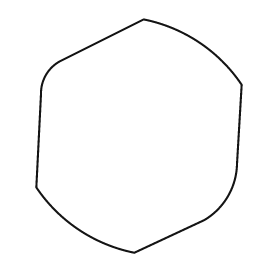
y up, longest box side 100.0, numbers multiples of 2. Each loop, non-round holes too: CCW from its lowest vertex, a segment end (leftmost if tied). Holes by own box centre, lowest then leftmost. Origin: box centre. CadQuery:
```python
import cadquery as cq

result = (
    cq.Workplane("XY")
    .moveTo(-2.0, -50.0)
    .lineTo(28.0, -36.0)
    .threePointArc((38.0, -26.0), (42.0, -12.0))
    .lineTo(44.0, 22.0)
    .threePointArc((26.0, 40.0), (2.0, 50.0))
    .lineTo(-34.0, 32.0)
    .threePointArc((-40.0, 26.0), (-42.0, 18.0))
    .lineTo(-44.0, -22.0)
    .threePointArc((-26.0, -40.0), (-2.0, -50.0))
    .close()
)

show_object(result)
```